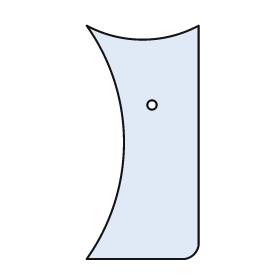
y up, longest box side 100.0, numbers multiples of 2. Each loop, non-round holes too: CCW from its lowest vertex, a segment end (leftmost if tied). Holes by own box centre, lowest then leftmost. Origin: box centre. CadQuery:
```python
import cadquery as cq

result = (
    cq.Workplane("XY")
    .moveTo(-24.0, -50.0)
    .lineTo(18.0, -50.0)
    .threePointArc((22.0, -48.0), (24.0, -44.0))
    .lineTo(24.0, 50.0)
    .threePointArc((0.0, 44.0), (-24.0, 50.0))
    .threePointArc((-8.0, 0.0), (-24.0, -50.0))
    .close()
    .moveTo(4.0, 16.0)
    .circle(2.0)
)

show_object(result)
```